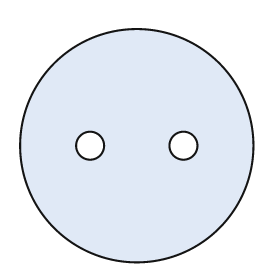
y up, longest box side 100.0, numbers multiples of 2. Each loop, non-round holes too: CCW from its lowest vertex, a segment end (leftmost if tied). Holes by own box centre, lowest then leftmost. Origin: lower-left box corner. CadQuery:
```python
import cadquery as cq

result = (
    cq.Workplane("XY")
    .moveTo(50.0, 50.0)
    .circle(50.0)
    .moveTo(30.0, 50.0)
    .circle(6.0)
    .moveTo(70.0, 50.0)
    .circle(6.0)
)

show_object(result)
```